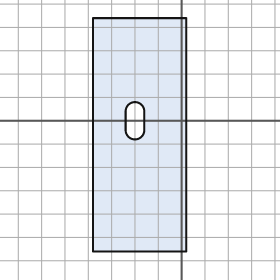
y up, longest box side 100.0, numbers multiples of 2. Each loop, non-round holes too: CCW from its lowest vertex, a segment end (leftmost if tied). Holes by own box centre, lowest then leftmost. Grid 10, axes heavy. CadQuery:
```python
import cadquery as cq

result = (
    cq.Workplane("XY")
    .moveTo(-38.0, -56.0)
    .lineTo(2.0, -56.0)
    .lineTo(2.0, 44.0)
    .lineTo(-38.0, 44.0)
    .close()
    .moveTo(-24.0, -4.0)
    .threePointArc((-20.0, -8.0), (-16.0, -4.0))
    .lineTo(-16.0, 4.0)
    .threePointArc((-20.0, 8.0), (-24.0, 4.0))
    .close()
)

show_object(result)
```